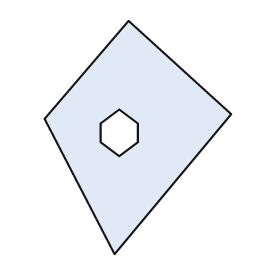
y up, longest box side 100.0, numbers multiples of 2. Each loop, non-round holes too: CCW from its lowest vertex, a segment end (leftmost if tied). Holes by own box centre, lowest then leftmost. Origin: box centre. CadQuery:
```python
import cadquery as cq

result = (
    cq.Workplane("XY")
    .moveTo(-10.0, -50.0)
    .lineTo(40.0, 10.0)
    .lineTo(-4.0, 50.0)
    .lineTo(-40.0, 8.0)
    .close()
    .moveTo(-8.0, -8.0)
    .lineTo(0.0, -2.0)
    .lineTo(0.0, 6.0)
    .lineTo(-8.0, 12.0)
    .lineTo(-16.0, 6.0)
    .lineTo(-16.0, -2.0)
    .close()
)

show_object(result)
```